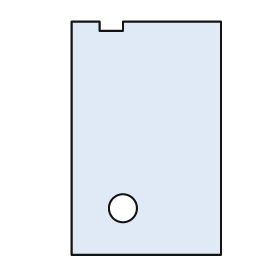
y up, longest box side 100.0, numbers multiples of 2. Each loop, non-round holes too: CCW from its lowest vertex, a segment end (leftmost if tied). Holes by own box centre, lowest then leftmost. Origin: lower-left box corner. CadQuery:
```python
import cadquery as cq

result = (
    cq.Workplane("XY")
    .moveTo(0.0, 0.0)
    .lineTo(64.0, 0.0)
    .lineTo(64.0, 100.0)
    .lineTo(22.0, 100.0)
    .lineTo(22.0, 96.0)
    .lineTo(12.0, 96.0)
    .lineTo(12.0, 100.0)
    .lineTo(0.0, 100.0)
    .close()
    .moveTo(22.0, 20.0)
    .circle(6.0)
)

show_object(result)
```